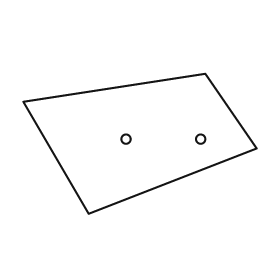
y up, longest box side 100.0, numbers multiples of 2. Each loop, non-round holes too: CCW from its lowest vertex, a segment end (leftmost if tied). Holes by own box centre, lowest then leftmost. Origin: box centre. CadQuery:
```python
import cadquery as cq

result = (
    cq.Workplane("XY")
    .moveTo(-22.0, -30.0)
    .lineTo(50.0, -2.0)
    .lineTo(28.0, 30.0)
    .lineTo(-50.0, 18.0)
    .close()
    .moveTo(-6.0, 2.0)
    .circle(2.0)
    .moveTo(26.0, 2.0)
    .circle(2.0)
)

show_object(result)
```